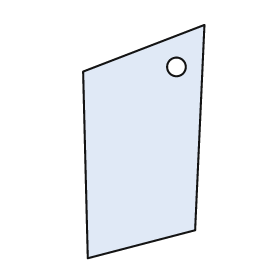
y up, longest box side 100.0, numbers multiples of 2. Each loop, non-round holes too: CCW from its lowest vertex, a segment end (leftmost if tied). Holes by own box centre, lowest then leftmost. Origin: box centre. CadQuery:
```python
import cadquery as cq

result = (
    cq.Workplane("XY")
    .moveTo(-24.0, -50.0)
    .lineTo(22.0, -38.0)
    .lineTo(26.0, 50.0)
    .lineTo(-26.0, 30.0)
    .close()
    .moveTo(14.0, 32.0)
    .circle(4.0)
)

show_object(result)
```